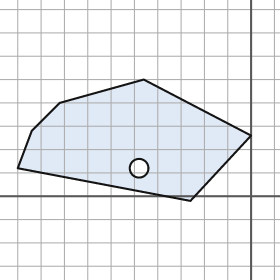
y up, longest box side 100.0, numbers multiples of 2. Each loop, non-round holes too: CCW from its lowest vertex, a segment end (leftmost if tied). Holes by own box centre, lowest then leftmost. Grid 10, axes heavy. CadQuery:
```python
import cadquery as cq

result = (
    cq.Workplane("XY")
    .moveTo(-26.0, -2.0)
    .lineTo(0.0, 26.0)
    .lineTo(-46.0, 50.0)
    .lineTo(-82.0, 40.0)
    .lineTo(-94.0, 28.0)
    .lineTo(-100.0, 12.0)
    .close()
    .moveTo(-48.0, 12.0)
    .circle(4.0)
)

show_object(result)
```